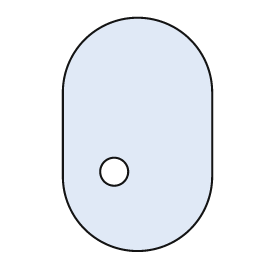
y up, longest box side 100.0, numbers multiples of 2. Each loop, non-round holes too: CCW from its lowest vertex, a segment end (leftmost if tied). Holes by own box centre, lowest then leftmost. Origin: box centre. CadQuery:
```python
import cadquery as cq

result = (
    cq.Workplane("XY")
    .moveTo(-32.0, -18.0)
    .threePointArc((0.0, -50.0), (32.0, -18.0))
    .lineTo(32.0, 18.0)
    .threePointArc((0.0, 50.0), (-32.0, 18.0))
    .close()
    .moveTo(-10.0, -16.0)
    .circle(6.0)
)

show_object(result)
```